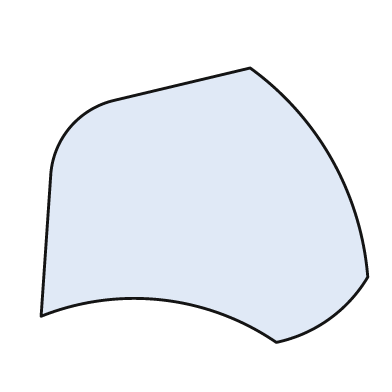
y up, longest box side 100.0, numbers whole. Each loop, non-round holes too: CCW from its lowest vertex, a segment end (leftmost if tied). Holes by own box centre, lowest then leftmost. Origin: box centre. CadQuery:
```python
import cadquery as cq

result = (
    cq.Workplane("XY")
    .moveTo(22.0, -42.0)
    .threePointArc((38.0, -35.0), (50.0, -22.0))
    .threePointArc((39.0, 14.0), (14.0, 42.0))
    .lineTo(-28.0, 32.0)
    .threePointArc((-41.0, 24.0), (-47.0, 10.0))
    .lineTo(-50.0, -34.0)
    .threePointArc((-13.0, -29.0), (22.0, -42.0))
    .close()
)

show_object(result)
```